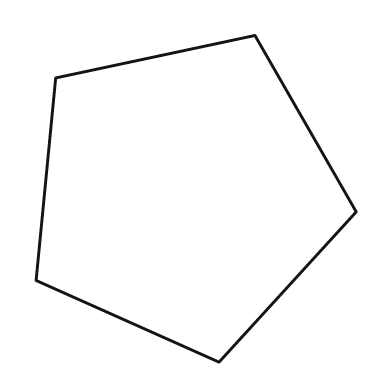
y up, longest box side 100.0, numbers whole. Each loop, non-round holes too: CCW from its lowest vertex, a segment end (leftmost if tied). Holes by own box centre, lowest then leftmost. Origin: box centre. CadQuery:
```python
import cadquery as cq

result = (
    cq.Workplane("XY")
    .moveTo(7.0, -50.0)
    .lineTo(49.0, -4.0)
    .lineTo(18.0, 50.0)
    .lineTo(-43.0, 37.0)
    .lineTo(-49.0, -25.0)
    .close()
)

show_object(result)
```